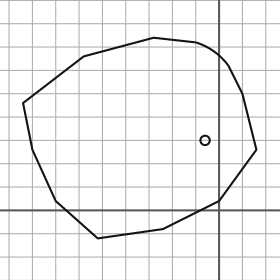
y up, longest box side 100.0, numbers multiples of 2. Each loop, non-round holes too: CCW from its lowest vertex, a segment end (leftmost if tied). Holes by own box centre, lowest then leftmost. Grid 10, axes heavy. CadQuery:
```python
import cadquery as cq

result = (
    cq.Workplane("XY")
    .moveTo(-52.0, -12.0)
    .lineTo(-24.0, -8.0)
    .lineTo(0.0, 4.0)
    .lineTo(16.0, 26.0)
    .lineTo(10.0, 50.0)
    .lineTo(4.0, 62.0)
    .threePointArc((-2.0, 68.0), (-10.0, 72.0))
    .lineTo(-28.0, 74.0)
    .lineTo(-58.0, 66.0)
    .lineTo(-84.0, 46.0)
    .lineTo(-80.0, 26.0)
    .lineTo(-70.0, 4.0)
    .close()
    .moveTo(-6.0, 30.0)
    .circle(2.0)
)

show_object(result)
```